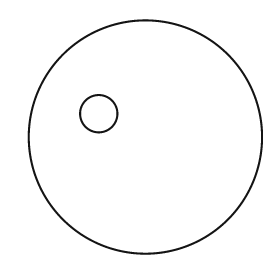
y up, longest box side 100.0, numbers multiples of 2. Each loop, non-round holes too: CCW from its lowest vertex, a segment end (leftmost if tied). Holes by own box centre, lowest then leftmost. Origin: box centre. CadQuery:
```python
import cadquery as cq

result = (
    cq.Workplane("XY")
    .moveTo(0.0, 0.0)
    .circle(50.0)
    .moveTo(-20.0, 10.0)
    .circle(8.0)
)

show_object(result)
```